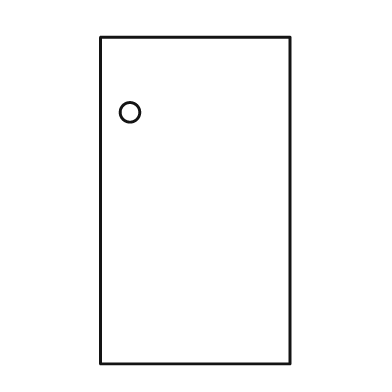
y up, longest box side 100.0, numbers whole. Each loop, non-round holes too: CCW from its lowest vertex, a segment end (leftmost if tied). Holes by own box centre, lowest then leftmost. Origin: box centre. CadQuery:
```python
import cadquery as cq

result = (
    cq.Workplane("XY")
    .moveTo(-29.0, -50.0)
    .lineTo(29.0, -50.0)
    .lineTo(29.0, 50.0)
    .lineTo(-29.0, 50.0)
    .close()
    .moveTo(-20.0, 27.0)
    .circle(3.0)
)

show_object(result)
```